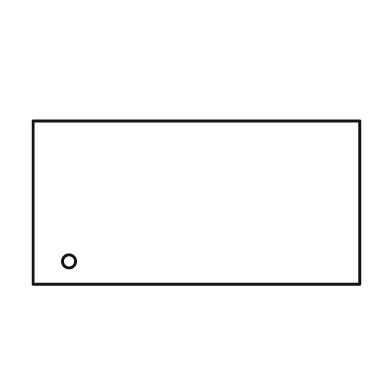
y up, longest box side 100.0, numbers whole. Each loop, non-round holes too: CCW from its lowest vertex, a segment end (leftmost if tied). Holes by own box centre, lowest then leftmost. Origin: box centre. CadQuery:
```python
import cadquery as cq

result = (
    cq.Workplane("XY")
    .moveTo(-50.0, -25.0)
    .lineTo(50.0, -25.0)
    .lineTo(50.0, 25.0)
    .lineTo(-50.0, 25.0)
    .close()
    .moveTo(-39.0, -18.0)
    .circle(2.0)
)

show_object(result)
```